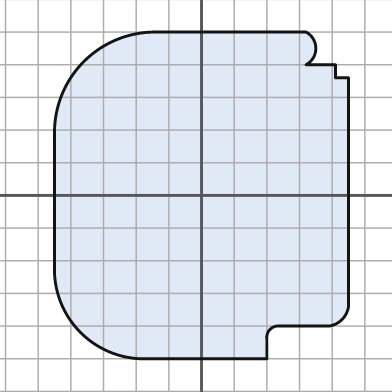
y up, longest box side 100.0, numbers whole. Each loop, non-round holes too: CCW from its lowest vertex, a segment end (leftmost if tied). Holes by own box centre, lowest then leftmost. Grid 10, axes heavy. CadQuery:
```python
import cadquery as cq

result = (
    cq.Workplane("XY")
    .moveTo(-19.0, -50.0)
    .lineTo(20.0, -50.0)
    .lineTo(20.0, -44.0)
    .threePointArc((21.0, -41.0), (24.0, -40.0))
    .lineTo(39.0, -40.0)
    .threePointArc((43.0, -38.0), (45.0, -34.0))
    .lineTo(45.0, 36.0)
    .lineTo(41.0, 36.0)
    .lineTo(41.0, 40.0)
    .lineTo(32.0, 40.0)
    .threePointArc((35.0, 45.0), (32.0, 50.0))
    .lineTo(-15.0, 50.0)
    .threePointArc((-36.0, 41.0), (-45.0, 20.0))
    .lineTo(-45.0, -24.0)
    .threePointArc((-37.0, -42.0), (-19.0, -50.0))
    .close()
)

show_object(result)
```